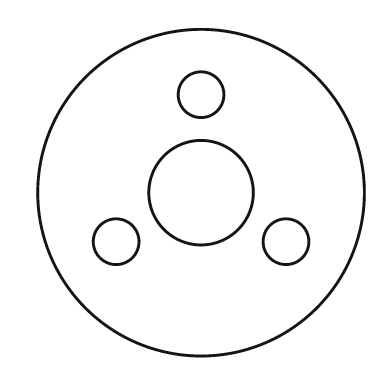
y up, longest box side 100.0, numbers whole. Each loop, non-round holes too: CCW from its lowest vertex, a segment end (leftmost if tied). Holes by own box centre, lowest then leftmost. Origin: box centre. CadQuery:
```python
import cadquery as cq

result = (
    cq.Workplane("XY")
    .moveTo(0.0, 0.0)
    .circle(50.0)
    .moveTo(-26.0, -15.0)
    .circle(7.0)
    .moveTo(26.0, -15.0)
    .circle(7.0)
    .moveTo(0.0, 0.0)
    .circle(16.0)
    .moveTo(0.0, 30.0)
    .circle(7.0)
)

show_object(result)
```